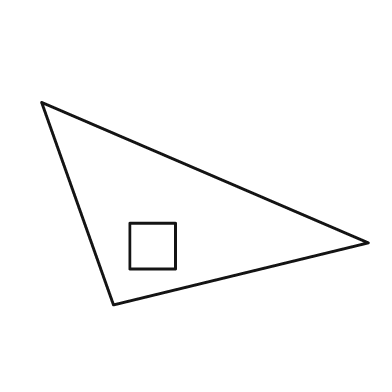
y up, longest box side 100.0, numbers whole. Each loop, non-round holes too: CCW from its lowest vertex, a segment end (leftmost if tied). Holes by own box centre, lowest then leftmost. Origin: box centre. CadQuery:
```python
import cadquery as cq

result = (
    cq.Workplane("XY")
    .moveTo(-28.0, -31.0)
    .lineTo(50.0, -12.0)
    .lineTo(-50.0, 31.0)
    .close()
    .moveTo(-23.0, -20.0)
    .lineTo(-9.0, -20.0)
    .lineTo(-9.0, -6.0)
    .lineTo(-23.0, -6.0)
    .close()
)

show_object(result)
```